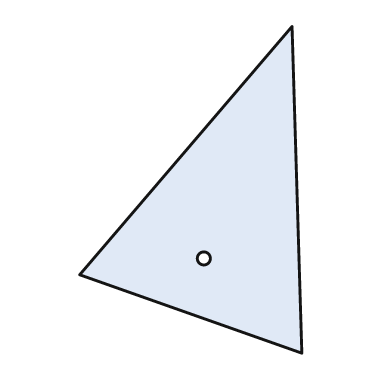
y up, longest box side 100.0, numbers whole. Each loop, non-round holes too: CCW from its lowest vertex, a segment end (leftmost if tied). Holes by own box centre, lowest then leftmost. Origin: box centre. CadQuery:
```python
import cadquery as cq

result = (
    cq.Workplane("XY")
    .moveTo(34.0, -50.0)
    .lineTo(31.0, 50.0)
    .lineTo(-34.0, -26.0)
    .close()
    .moveTo(4.0, -21.0)
    .circle(2.0)
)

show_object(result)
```